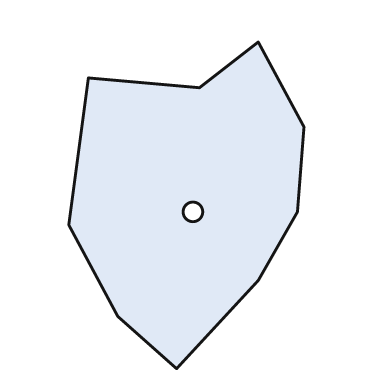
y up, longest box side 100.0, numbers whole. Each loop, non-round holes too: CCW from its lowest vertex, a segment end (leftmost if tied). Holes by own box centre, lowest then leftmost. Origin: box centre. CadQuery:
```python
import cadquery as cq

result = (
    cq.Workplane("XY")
    .moveTo(-3.0, -50.0)
    .lineTo(22.0, -23.0)
    .lineTo(34.0, -2.0)
    .lineTo(36.0, 24.0)
    .lineTo(22.0, 50.0)
    .lineTo(4.0, 36.0)
    .lineTo(-30.0, 39.0)
    .lineTo(-36.0, -6.0)
    .lineTo(-21.0, -34.0)
    .close()
    .moveTo(2.0, -2.0)
    .circle(3.0)
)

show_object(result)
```